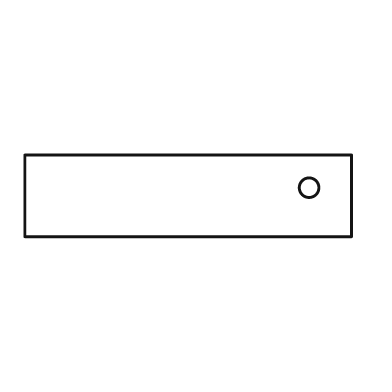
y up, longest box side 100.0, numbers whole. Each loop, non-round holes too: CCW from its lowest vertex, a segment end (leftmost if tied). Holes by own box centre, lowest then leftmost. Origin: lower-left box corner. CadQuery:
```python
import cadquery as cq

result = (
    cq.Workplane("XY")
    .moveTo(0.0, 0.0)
    .lineTo(100.0, 0.0)
    .lineTo(100.0, 25.0)
    .lineTo(0.0, 25.0)
    .close()
    .moveTo(87.0, 15.0)
    .circle(3.0)
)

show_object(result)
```